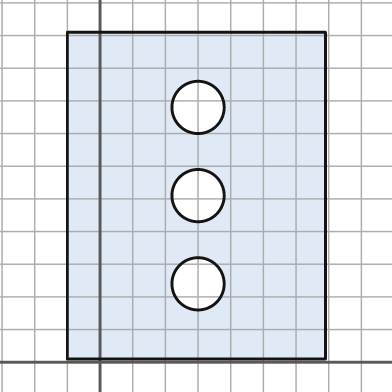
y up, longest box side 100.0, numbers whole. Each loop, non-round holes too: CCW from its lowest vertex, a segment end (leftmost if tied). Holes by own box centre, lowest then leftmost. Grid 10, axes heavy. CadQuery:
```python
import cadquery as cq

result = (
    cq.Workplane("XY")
    .moveTo(-10.0, 1.0)
    .lineTo(69.0, 1.0)
    .lineTo(69.0, 101.0)
    .lineTo(-10.0, 101.0)
    .close()
    .moveTo(30.0, 24.0)
    .circle(8.0)
    .moveTo(30.0, 51.0)
    .circle(8.0)
    .moveTo(30.0, 78.0)
    .circle(8.0)
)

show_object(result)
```